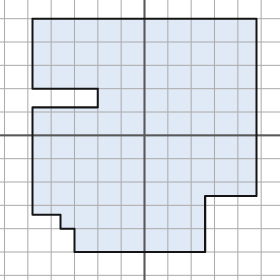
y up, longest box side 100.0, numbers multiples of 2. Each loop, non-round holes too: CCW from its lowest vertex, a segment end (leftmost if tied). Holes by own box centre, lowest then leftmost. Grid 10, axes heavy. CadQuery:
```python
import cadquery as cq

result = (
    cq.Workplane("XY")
    .moveTo(-30.0, -50.0)
    .lineTo(26.0, -50.0)
    .lineTo(26.0, -26.0)
    .lineTo(48.0, -26.0)
    .lineTo(48.0, 50.0)
    .lineTo(-48.0, 50.0)
    .lineTo(-48.0, 20.0)
    .lineTo(-20.0, 20.0)
    .lineTo(-20.0, 12.0)
    .lineTo(-48.0, 12.0)
    .lineTo(-48.0, -34.0)
    .lineTo(-36.0, -34.0)
    .lineTo(-36.0, -40.0)
    .lineTo(-30.0, -40.0)
    .close()
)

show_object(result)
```